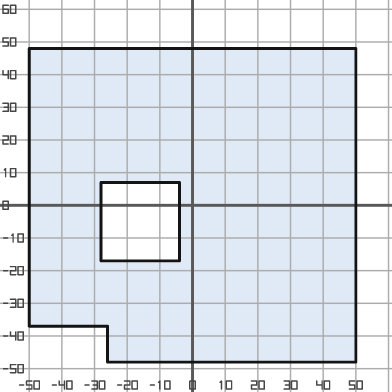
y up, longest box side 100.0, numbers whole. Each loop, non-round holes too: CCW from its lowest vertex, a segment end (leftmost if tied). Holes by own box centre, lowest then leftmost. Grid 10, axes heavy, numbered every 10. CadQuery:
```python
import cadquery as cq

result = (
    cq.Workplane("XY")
    .moveTo(-26.0, -48.0)
    .lineTo(50.0, -48.0)
    .lineTo(50.0, 48.0)
    .lineTo(-50.0, 48.0)
    .lineTo(-50.0, -37.0)
    .lineTo(-26.0, -37.0)
    .close()
    .moveTo(-28.0, -17.0)
    .lineTo(-4.0, -17.0)
    .lineTo(-4.0, 7.0)
    .lineTo(-28.0, 7.0)
    .close()
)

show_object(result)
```